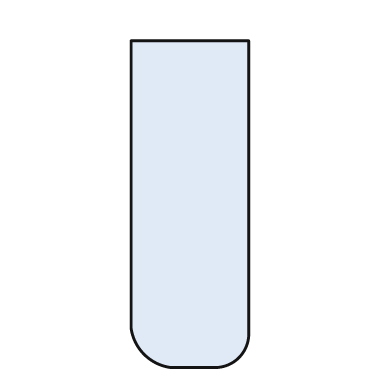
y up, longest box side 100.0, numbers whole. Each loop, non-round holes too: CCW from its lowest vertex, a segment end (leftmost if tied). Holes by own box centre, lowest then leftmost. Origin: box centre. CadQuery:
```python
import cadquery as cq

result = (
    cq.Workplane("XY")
    .moveTo(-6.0, -50.0)
    .lineTo(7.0, -50.0)
    .threePointArc((15.0, -47.0), (18.0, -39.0))
    .lineTo(18.0, 50.0)
    .lineTo(-18.0, 50.0)
    .lineTo(-18.0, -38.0)
    .threePointArc((-14.0, -46.0), (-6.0, -50.0))
    .close()
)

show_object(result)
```